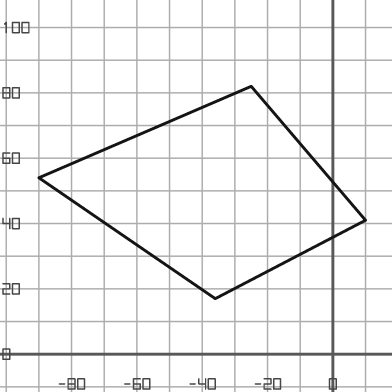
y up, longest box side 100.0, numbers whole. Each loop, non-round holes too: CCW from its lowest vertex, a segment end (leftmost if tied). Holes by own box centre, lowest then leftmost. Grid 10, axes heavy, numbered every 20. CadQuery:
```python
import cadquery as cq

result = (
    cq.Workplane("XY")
    .moveTo(-36.0, 17.0)
    .lineTo(10.0, 41.0)
    .lineTo(-25.0, 82.0)
    .lineTo(-90.0, 54.0)
    .close()
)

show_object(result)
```